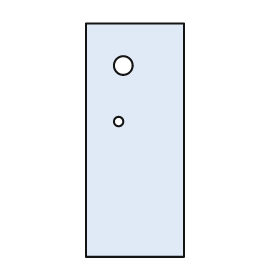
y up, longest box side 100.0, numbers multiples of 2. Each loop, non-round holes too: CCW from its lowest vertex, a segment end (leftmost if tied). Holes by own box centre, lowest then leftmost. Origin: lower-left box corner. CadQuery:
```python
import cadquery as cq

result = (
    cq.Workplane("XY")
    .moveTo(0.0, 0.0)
    .lineTo(42.0, 0.0)
    .lineTo(42.0, 100.0)
    .lineTo(0.0, 100.0)
    .close()
    .moveTo(14.0, 58.0)
    .circle(2.0)
    .moveTo(16.0, 82.0)
    .circle(4.0)
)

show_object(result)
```